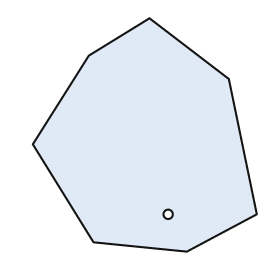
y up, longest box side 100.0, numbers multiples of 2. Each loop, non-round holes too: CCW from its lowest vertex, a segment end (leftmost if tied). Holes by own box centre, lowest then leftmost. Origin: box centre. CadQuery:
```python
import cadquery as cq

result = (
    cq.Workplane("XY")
    .moveTo(18.0, -50.0)
    .lineTo(48.0, -34.0)
    .lineTo(36.0, 24.0)
    .lineTo(2.0, 50.0)
    .lineTo(-24.0, 34.0)
    .lineTo(-48.0, -4.0)
    .lineTo(-22.0, -46.0)
    .close()
    .moveTo(10.0, -34.0)
    .circle(2.0)
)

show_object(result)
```